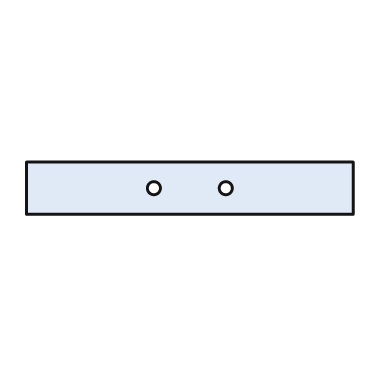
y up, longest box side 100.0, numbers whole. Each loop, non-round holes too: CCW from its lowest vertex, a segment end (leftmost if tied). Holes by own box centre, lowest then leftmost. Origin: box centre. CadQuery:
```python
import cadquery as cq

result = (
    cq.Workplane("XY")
    .moveTo(-50.0, -8.0)
    .lineTo(50.0, -8.0)
    .lineTo(50.0, 8.0)
    .lineTo(-50.0, 8.0)
    .close()
    .moveTo(-11.0, 0.0)
    .circle(2.0)
    .moveTo(11.0, 0.0)
    .circle(2.0)
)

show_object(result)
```